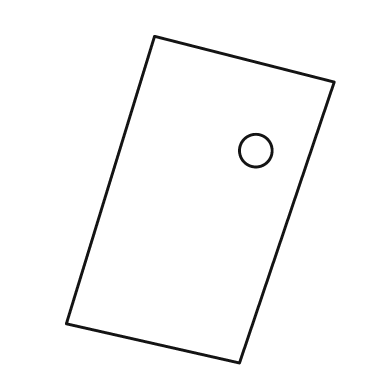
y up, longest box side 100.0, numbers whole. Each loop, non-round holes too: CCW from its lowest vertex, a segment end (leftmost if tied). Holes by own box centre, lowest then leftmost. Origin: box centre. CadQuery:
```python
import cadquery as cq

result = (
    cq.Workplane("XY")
    .moveTo(12.0, -50.0)
    .lineTo(41.0, 36.0)
    .lineTo(-14.0, 50.0)
    .lineTo(-41.0, -38.0)
    .close()
    .moveTo(17.0, 15.0)
    .circle(5.0)
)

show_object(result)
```